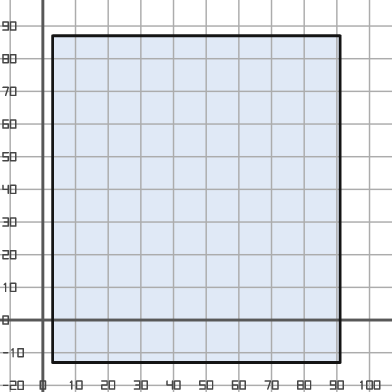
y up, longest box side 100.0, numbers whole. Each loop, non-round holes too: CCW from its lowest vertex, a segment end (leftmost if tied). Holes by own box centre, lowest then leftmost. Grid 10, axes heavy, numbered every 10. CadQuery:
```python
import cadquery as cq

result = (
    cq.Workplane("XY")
    .moveTo(3.0, -13.0)
    .lineTo(91.0, -13.0)
    .lineTo(91.0, 87.0)
    .lineTo(3.0, 87.0)
    .close()
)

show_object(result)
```